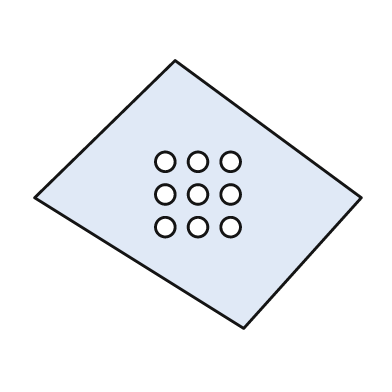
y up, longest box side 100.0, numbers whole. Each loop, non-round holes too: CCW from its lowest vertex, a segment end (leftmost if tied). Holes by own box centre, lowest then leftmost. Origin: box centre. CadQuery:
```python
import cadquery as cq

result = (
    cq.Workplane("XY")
    .moveTo(14.0, -41.0)
    .lineTo(50.0, -1.0)
    .lineTo(-7.0, 41.0)
    .lineTo(-50.0, -1.0)
    .close()
    .moveTo(-10.0, -10.0)
    .circle(3.0)
    .moveTo(0.0, -10.0)
    .circle(3.0)
    .moveTo(10.0, -10.0)
    .circle(3.0)
    .moveTo(-10.0, 0.0)
    .circle(3.0)
    .moveTo(0.0, 0.0)
    .circle(3.0)
    .moveTo(10.0, 0.0)
    .circle(3.0)
    .moveTo(-10.0, 10.0)
    .circle(3.0)
    .moveTo(0.0, 10.0)
    .circle(3.0)
    .moveTo(10.0, 10.0)
    .circle(3.0)
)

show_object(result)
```